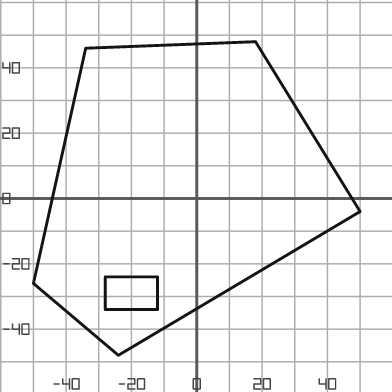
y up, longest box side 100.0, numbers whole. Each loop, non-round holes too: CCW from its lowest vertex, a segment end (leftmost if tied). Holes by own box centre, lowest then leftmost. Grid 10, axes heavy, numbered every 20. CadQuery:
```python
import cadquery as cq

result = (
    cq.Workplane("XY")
    .moveTo(-24.0, -48.0)
    .lineTo(50.0, -4.0)
    .lineTo(18.0, 48.0)
    .lineTo(-34.0, 46.0)
    .lineTo(-50.0, -26.0)
    .close()
    .moveTo(-28.0, -34.0)
    .lineTo(-12.0, -34.0)
    .lineTo(-12.0, -24.0)
    .lineTo(-28.0, -24.0)
    .close()
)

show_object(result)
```